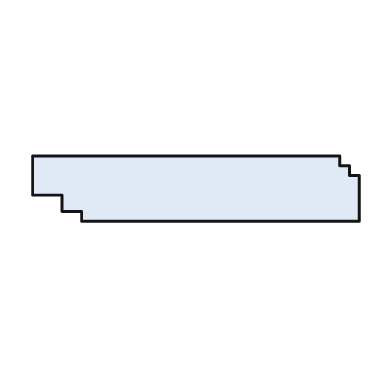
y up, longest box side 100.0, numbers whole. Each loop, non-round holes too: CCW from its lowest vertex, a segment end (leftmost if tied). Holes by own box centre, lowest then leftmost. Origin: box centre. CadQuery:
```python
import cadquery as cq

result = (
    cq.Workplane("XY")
    .moveTo(-35.0, -10.0)
    .lineTo(50.0, -10.0)
    .lineTo(50.0, 4.0)
    .lineTo(47.0, 4.0)
    .lineTo(47.0, 7.0)
    .lineTo(44.0, 7.0)
    .lineTo(44.0, 10.0)
    .lineTo(-50.0, 10.0)
    .lineTo(-50.0, -2.0)
    .lineTo(-41.0, -2.0)
    .lineTo(-41.0, -7.0)
    .lineTo(-35.0, -7.0)
    .close()
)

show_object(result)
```